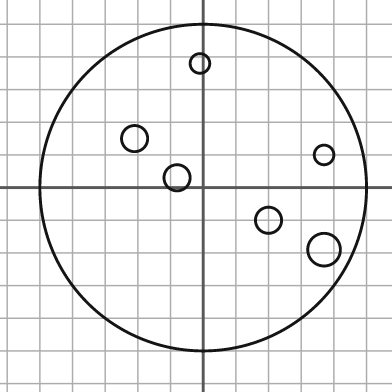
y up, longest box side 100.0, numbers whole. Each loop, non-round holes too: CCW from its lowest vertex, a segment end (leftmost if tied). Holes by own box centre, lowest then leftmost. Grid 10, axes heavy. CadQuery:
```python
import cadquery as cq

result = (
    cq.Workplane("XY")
    .moveTo(0.0, 0.0)
    .circle(50.0)
    .moveTo(37.0, -19.0)
    .circle(5.0)
    .moveTo(20.0, -10.0)
    .circle(4.0)
    .moveTo(-8.0, 3.0)
    .circle(4.0)
    .moveTo(37.0, 10.0)
    .circle(3.0)
    .moveTo(-21.0, 15.0)
    .circle(4.0)
    .moveTo(-1.0, 38.0)
    .circle(3.0)
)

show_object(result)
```